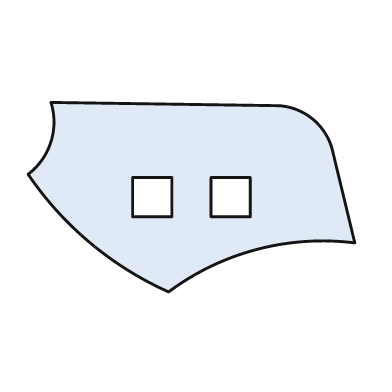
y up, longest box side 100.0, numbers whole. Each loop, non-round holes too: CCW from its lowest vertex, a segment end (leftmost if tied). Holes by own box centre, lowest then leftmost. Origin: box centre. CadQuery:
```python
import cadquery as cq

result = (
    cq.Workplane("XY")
    .moveTo(-7.0, -29.0)
    .threePointArc((20.0, -16.0), (50.0, -14.0))
    .lineTo(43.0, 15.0)
    .threePointArc((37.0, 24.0), (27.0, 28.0))
    .lineTo(-43.0, 29.0)
    .threePointArc((-43.0, 17.0), (-50.0, 7.0))
    .threePointArc((-31.0, -14.0), (-7.0, -29.0))
    .close()
    .moveTo(-18.0, -6.0)
    .lineTo(-6.0, -6.0)
    .lineTo(-6.0, 6.0)
    .lineTo(-18.0, 6.0)
    .close()
    .moveTo(6.0, -6.0)
    .lineTo(18.0, -6.0)
    .lineTo(18.0, 6.0)
    .lineTo(6.0, 6.0)
    .close()
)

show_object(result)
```